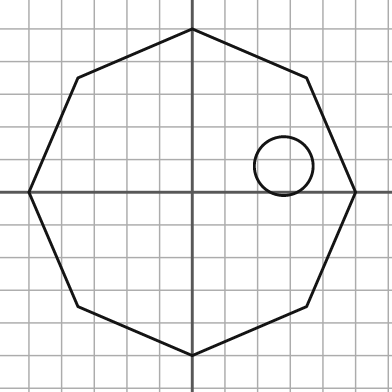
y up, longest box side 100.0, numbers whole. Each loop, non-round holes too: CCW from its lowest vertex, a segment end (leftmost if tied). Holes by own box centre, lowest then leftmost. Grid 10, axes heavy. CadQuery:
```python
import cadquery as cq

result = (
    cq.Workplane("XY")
    .moveTo(0.0, -50.0)
    .lineTo(35.0, -35.0)
    .lineTo(50.0, 0.0)
    .lineTo(35.0, 35.0)
    .lineTo(0.0, 50.0)
    .lineTo(-35.0, 35.0)
    .lineTo(-50.0, 0.0)
    .lineTo(-35.0, -35.0)
    .close()
    .moveTo(28.0, 8.0)
    .circle(9.0)
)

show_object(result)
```